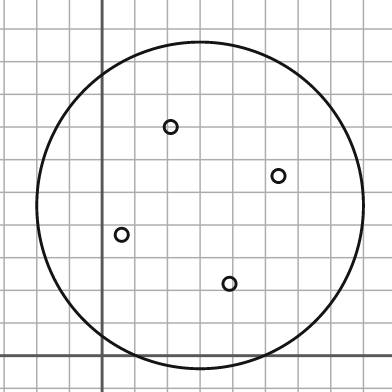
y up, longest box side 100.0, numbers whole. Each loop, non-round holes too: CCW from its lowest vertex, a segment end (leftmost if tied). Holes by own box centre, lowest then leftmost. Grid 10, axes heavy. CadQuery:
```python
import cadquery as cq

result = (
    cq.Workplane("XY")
    .moveTo(30.0, 46.0)
    .circle(50.0)
    .moveTo(39.0, 22.0)
    .circle(2.0)
    .moveTo(6.0, 37.0)
    .circle(2.0)
    .moveTo(54.0, 55.0)
    .circle(2.0)
    .moveTo(21.0, 70.0)
    .circle(2.0)
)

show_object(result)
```